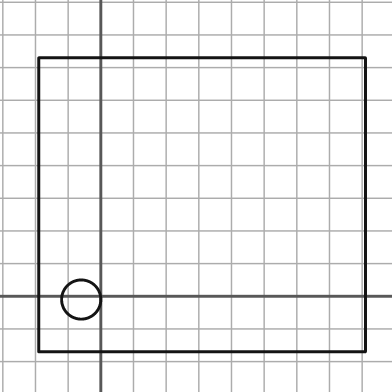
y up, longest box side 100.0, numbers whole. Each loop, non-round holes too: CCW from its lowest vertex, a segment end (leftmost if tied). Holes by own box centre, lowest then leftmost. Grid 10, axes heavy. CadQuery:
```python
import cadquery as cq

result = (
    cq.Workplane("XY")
    .moveTo(-19.0, -17.0)
    .lineTo(81.0, -17.0)
    .lineTo(81.0, 73.0)
    .lineTo(-19.0, 73.0)
    .close()
    .moveTo(-6.0, -1.0)
    .circle(6.0)
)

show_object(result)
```